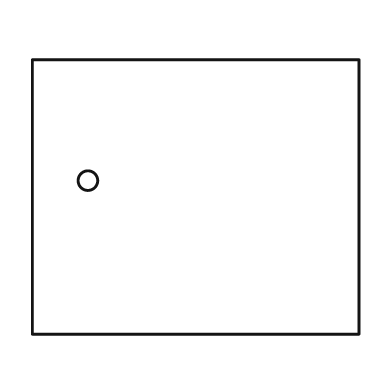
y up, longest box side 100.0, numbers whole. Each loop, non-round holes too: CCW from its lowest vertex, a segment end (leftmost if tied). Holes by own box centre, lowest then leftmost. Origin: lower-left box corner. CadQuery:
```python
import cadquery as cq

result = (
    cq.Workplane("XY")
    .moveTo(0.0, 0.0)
    .lineTo(100.0, 0.0)
    .lineTo(100.0, 84.0)
    .lineTo(0.0, 84.0)
    .close()
    .moveTo(17.0, 47.0)
    .circle(3.0)
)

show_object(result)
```